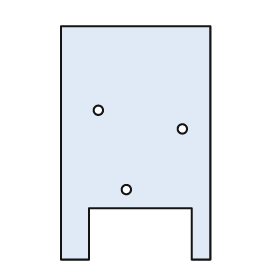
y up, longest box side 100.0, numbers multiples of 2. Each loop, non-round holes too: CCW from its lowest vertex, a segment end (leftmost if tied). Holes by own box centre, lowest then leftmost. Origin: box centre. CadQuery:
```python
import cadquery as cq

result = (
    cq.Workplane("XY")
    .moveTo(-32.0, -50.0)
    .lineTo(-20.0, -50.0)
    .lineTo(-20.0, -28.0)
    .lineTo(24.0, -28.0)
    .lineTo(24.0, -50.0)
    .lineTo(32.0, -50.0)
    .lineTo(32.0, 50.0)
    .lineTo(-32.0, 50.0)
    .close()
    .moveTo(-4.0, -20.0)
    .circle(2.0)
    .moveTo(20.0, 6.0)
    .circle(2.0)
    .moveTo(-16.0, 14.0)
    .circle(2.0)
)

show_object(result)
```